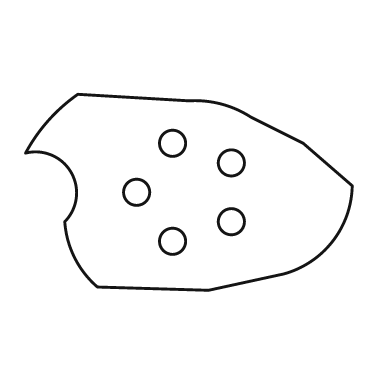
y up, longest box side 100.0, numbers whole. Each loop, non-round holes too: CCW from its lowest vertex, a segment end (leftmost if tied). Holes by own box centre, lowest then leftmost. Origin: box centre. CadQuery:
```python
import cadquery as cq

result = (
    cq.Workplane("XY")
    .moveTo(6.0, -30.0)
    .lineTo(29.0, -25.0)
    .threePointArc((44.0, -15.0), (50.0, 2.0))
    .lineTo(35.0, 15.0)
    .lineTo(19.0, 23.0)
    .threePointArc((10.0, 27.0), (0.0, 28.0))
    .lineTo(-34.0, 30.0)
    .threePointArc((-43.0, 22.0), (-50.0, 12.0))
    .threePointArc((-36.0, 6.0), (-38.0, -9.0))
    .threePointArc((-35.0, -20.0), (-28.0, -29.0))
    .close()
    .moveTo(-5.0, -15.0)
    .circle(4.0)
    .moveTo(13.0, -9.0)
    .circle(4.0)
    .moveTo(-16.0, 0.0)
    .circle(4.0)
    .moveTo(13.0, 9.0)
    .circle(4.0)
    .moveTo(-5.0, 15.0)
    .circle(4.0)
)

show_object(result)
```